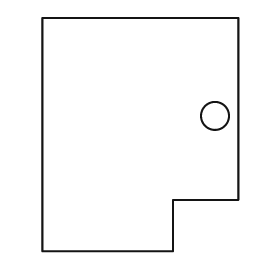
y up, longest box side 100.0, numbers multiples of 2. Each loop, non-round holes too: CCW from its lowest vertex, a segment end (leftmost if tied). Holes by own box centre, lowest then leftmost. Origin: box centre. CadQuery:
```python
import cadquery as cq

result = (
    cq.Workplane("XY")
    .moveTo(-42.0, -50.0)
    .lineTo(14.0, -50.0)
    .lineTo(14.0, -28.0)
    .lineTo(42.0, -28.0)
    .lineTo(42.0, 50.0)
    .lineTo(-42.0, 50.0)
    .close()
    .moveTo(32.0, 8.0)
    .circle(6.0)
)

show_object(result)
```